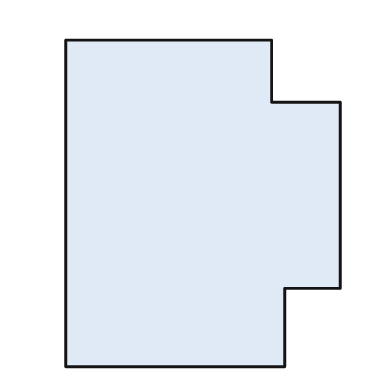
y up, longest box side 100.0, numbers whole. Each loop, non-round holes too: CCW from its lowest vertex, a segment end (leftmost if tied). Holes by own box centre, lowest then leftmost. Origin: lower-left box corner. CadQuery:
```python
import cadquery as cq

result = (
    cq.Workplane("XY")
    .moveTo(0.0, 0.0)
    .lineTo(67.0, 0.0)
    .lineTo(67.0, 24.0)
    .lineTo(84.0, 24.0)
    .lineTo(84.0, 81.0)
    .lineTo(63.0, 81.0)
    .lineTo(63.0, 100.0)
    .lineTo(0.0, 100.0)
    .close()
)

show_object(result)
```